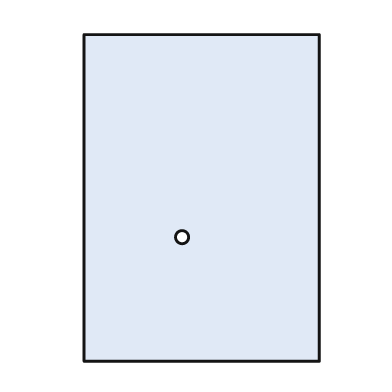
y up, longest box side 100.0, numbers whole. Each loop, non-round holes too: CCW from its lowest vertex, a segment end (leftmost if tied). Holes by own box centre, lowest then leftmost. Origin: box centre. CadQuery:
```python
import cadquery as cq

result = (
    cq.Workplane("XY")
    .moveTo(-36.0, -50.0)
    .lineTo(36.0, -50.0)
    .lineTo(36.0, 50.0)
    .lineTo(-36.0, 50.0)
    .close()
    .moveTo(-6.0, -12.0)
    .circle(2.0)
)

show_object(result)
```